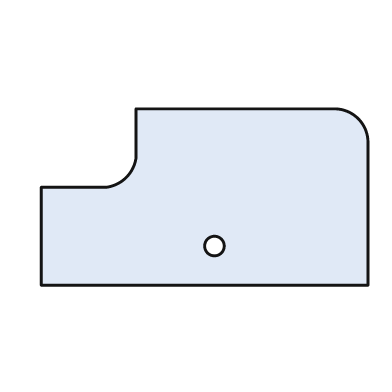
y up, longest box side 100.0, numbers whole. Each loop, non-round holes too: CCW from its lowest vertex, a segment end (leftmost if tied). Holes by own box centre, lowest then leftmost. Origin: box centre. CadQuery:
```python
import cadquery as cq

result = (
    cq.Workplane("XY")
    .moveTo(-50.0, -27.0)
    .lineTo(50.0, -27.0)
    .lineTo(50.0, 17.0)
    .threePointArc((47.0, 24.0), (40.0, 27.0))
    .lineTo(-21.0, 27.0)
    .lineTo(-21.0, 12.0)
    .threePointArc((-24.0, 6.0), (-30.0, 3.0))
    .lineTo(-50.0, 3.0)
    .close()
    .moveTo(3.0, -15.0)
    .circle(3.0)
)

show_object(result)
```